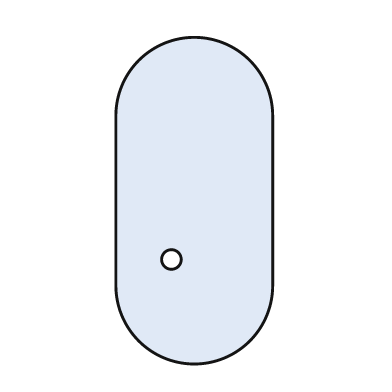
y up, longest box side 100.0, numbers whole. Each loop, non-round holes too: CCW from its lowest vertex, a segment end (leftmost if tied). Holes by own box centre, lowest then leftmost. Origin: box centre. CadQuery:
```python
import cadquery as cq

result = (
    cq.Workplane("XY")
    .moveTo(-24.0, -26.0)
    .threePointArc((0.0, -50.0), (24.0, -26.0))
    .lineTo(24.0, 26.0)
    .threePointArc((0.0, 50.0), (-24.0, 26.0))
    .close()
    .moveTo(-7.0, -18.0)
    .circle(3.0)
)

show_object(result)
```